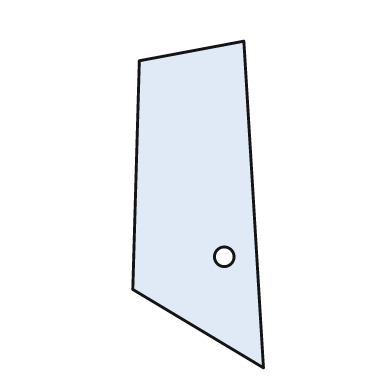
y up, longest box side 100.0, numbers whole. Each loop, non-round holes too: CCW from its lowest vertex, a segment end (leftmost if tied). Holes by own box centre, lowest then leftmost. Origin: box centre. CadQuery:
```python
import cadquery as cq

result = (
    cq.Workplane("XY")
    .moveTo(20.0, -50.0)
    .lineTo(14.0, 50.0)
    .lineTo(-18.0, 44.0)
    .lineTo(-20.0, -26.0)
    .close()
    .moveTo(8.0, -16.0)
    .circle(3.0)
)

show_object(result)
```